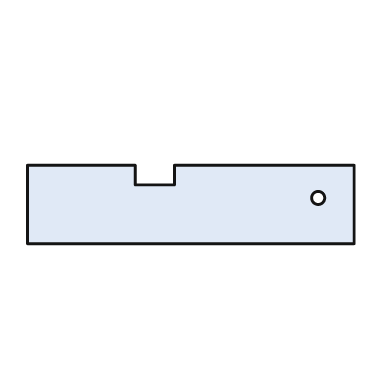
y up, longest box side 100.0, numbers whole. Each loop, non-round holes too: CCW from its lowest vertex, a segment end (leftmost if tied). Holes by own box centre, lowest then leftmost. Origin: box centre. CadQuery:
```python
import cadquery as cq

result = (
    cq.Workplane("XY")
    .moveTo(-50.0, -12.0)
    .lineTo(50.0, -12.0)
    .lineTo(50.0, 12.0)
    .lineTo(-5.0, 12.0)
    .lineTo(-5.0, 6.0)
    .lineTo(-17.0, 6.0)
    .lineTo(-17.0, 12.0)
    .lineTo(-50.0, 12.0)
    .close()
    .moveTo(39.0, 2.0)
    .circle(2.0)
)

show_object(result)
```